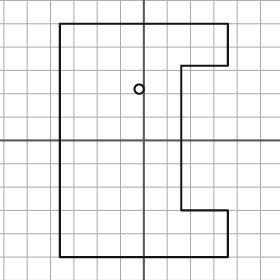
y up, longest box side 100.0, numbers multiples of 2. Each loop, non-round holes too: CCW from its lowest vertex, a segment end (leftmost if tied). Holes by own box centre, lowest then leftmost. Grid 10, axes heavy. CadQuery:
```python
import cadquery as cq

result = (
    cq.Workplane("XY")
    .moveTo(-36.0, -50.0)
    .lineTo(36.0, -50.0)
    .lineTo(36.0, -30.0)
    .lineTo(16.0, -30.0)
    .lineTo(16.0, 32.0)
    .lineTo(36.0, 32.0)
    .lineTo(36.0, 50.0)
    .lineTo(-36.0, 50.0)
    .close()
    .moveTo(-2.0, 22.0)
    .circle(2.0)
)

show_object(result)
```